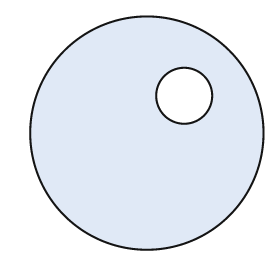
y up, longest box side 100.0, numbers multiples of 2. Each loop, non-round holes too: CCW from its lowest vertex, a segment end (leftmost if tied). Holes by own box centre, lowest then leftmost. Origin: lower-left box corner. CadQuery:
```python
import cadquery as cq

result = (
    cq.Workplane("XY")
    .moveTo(50.0, 50.0)
    .circle(50.0)
    .moveTo(66.0, 66.0)
    .circle(12.0)
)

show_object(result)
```